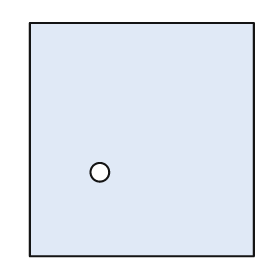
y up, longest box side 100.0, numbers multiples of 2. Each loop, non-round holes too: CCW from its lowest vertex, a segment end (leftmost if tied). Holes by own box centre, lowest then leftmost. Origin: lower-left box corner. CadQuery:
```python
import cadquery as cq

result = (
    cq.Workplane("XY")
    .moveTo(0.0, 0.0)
    .lineTo(96.0, 0.0)
    .lineTo(96.0, 100.0)
    .lineTo(0.0, 100.0)
    .close()
    .moveTo(30.0, 36.0)
    .circle(4.0)
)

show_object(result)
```